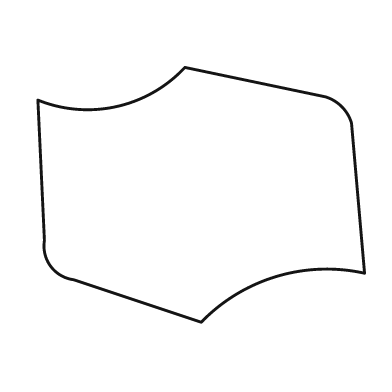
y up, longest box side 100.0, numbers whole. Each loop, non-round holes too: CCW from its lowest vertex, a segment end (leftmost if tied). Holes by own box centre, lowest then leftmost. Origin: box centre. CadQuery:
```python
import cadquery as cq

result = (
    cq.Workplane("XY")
    .moveTo(0.0, -39.0)
    .threePointArc((23.0, -25.0), (50.0, -24.0))
    .lineTo(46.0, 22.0)
    .threePointArc((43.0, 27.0), (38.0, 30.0))
    .lineTo(-5.0, 39.0)
    .threePointArc((-26.0, 27.0), (-50.0, 29.0))
    .lineTo(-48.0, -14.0)
    .threePointArc((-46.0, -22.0), (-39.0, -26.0))
    .close()
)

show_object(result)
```